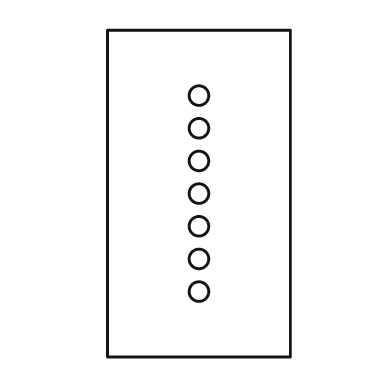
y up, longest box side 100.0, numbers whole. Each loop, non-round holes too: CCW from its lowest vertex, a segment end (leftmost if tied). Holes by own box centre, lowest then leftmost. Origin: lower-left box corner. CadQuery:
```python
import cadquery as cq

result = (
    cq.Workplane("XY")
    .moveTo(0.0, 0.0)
    .lineTo(56.0, 0.0)
    .lineTo(56.0, 100.0)
    .lineTo(0.0, 100.0)
    .close()
    .moveTo(28.0, 20.0)
    .circle(3.0)
    .moveTo(28.0, 30.0)
    .circle(3.0)
    .moveTo(28.0, 40.0)
    .circle(3.0)
    .moveTo(28.0, 50.0)
    .circle(3.0)
    .moveTo(28.0, 60.0)
    .circle(3.0)
    .moveTo(28.0, 70.0)
    .circle(3.0)
    .moveTo(28.0, 80.0)
    .circle(3.0)
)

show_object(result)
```